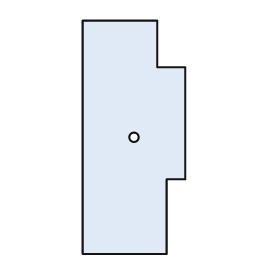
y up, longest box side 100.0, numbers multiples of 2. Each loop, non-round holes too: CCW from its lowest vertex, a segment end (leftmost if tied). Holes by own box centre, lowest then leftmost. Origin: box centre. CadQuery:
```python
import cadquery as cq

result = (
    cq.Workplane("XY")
    .moveTo(-22.0, -50.0)
    .lineTo(14.0, -50.0)
    .lineTo(14.0, -18.0)
    .lineTo(22.0, -18.0)
    .lineTo(22.0, 30.0)
    .lineTo(10.0, 30.0)
    .lineTo(10.0, 50.0)
    .lineTo(-22.0, 50.0)
    .close()
    .moveTo(0.0, 0.0)
    .circle(2.0)
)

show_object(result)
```